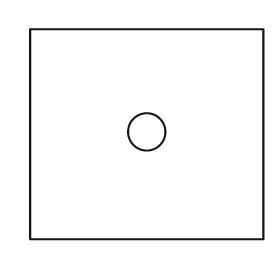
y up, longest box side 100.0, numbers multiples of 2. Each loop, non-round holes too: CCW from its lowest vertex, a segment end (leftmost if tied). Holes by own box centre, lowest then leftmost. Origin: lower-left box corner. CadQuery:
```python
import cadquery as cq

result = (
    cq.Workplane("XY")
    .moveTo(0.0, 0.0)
    .lineTo(100.0, 0.0)
    .lineTo(100.0, 90.0)
    .lineTo(0.0, 90.0)
    .close()
    .moveTo(50.0, 46.0)
    .circle(8.0)
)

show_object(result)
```